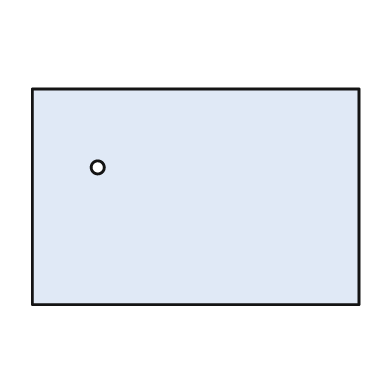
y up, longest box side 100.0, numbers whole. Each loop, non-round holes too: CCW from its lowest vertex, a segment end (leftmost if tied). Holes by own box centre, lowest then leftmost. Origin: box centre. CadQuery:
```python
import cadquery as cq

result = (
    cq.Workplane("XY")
    .moveTo(-50.0, -33.0)
    .lineTo(50.0, -33.0)
    .lineTo(50.0, 33.0)
    .lineTo(-50.0, 33.0)
    .close()
    .moveTo(-30.0, 9.0)
    .circle(2.0)
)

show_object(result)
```